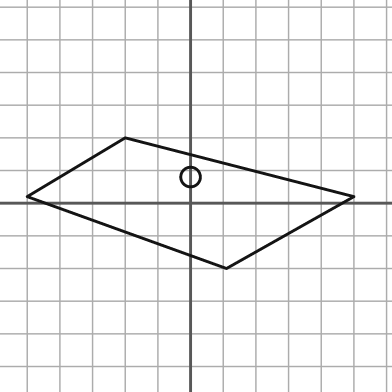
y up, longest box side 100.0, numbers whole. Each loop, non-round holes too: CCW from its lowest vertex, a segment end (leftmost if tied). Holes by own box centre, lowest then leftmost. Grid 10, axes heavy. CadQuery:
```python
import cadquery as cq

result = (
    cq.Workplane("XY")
    .moveTo(11.0, -20.0)
    .lineTo(50.0, 2.0)
    .lineTo(-20.0, 20.0)
    .lineTo(-50.0, 2.0)
    .close()
    .moveTo(0.0, 8.0)
    .circle(3.0)
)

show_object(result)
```